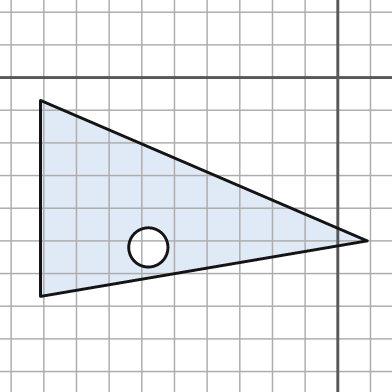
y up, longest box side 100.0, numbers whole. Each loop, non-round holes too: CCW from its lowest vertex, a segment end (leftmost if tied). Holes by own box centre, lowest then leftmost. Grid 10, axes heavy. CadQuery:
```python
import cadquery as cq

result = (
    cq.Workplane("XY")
    .moveTo(-91.0, -67.0)
    .lineTo(9.0, -50.0)
    .lineTo(-91.0, -7.0)
    .close()
    .moveTo(-58.0, -52.0)
    .circle(6.0)
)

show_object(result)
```